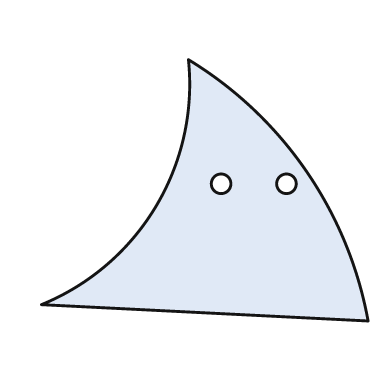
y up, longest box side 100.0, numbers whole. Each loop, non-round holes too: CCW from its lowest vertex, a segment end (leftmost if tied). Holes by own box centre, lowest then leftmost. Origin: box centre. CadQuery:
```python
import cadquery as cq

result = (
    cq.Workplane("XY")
    .moveTo(50.0, -40.0)
    .threePointArc((31.0, 6.0), (-5.0, 40.0))
    .threePointArc((-15.0, -5.0), (-50.0, -35.0))
    .close()
    .moveTo(5.0, 2.0)
    .circle(3.0)
    .moveTo(25.0, 2.0)
    .circle(3.0)
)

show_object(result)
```